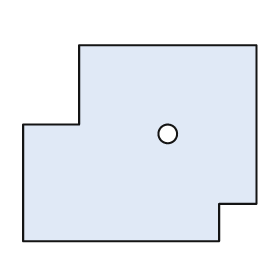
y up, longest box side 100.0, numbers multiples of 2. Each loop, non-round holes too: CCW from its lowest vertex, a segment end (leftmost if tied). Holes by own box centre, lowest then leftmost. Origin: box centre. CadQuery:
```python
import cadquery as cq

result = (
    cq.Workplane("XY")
    .moveTo(-50.0, -42.0)
    .lineTo(34.0, -42.0)
    .lineTo(34.0, -26.0)
    .lineTo(50.0, -26.0)
    .lineTo(50.0, 42.0)
    .lineTo(-26.0, 42.0)
    .lineTo(-26.0, 8.0)
    .lineTo(-50.0, 8.0)
    .close()
    .moveTo(12.0, 4.0)
    .circle(4.0)
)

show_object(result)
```